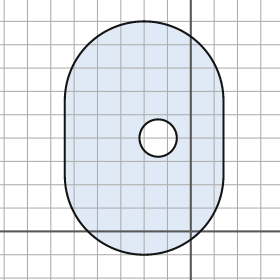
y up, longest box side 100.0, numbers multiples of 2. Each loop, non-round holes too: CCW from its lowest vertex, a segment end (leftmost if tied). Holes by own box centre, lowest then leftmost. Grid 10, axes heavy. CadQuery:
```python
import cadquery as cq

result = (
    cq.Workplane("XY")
    .moveTo(-54.0, 24.0)
    .threePointArc((-20.0, -10.0), (14.0, 24.0))
    .lineTo(14.0, 56.0)
    .threePointArc((-20.0, 90.0), (-54.0, 56.0))
    .close()
    .moveTo(-14.0, 40.0)
    .circle(8.0)
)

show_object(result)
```